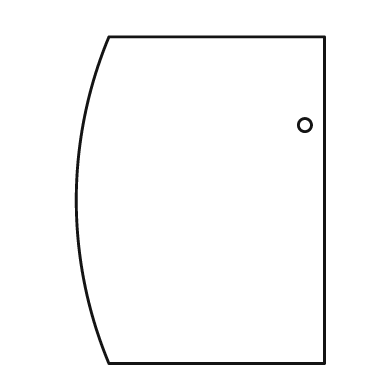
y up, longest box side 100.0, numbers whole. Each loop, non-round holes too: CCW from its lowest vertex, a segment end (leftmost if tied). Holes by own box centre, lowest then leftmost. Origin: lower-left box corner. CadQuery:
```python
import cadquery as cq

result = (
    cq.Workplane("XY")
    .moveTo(10.0, 0.0)
    .lineTo(76.0, 0.0)
    .lineTo(76.0, 100.0)
    .lineTo(10.0, 100.0)
    .threePointArc((0.0, 50.0), (10.0, 0.0))
    .close()
    .moveTo(70.0, 73.0)
    .circle(2.0)
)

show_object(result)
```